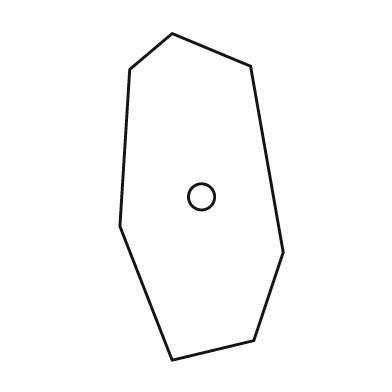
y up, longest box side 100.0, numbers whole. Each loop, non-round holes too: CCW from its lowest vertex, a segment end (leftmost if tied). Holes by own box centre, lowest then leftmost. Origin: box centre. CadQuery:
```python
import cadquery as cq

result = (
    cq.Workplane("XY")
    .moveTo(-9.0, -50.0)
    .lineTo(16.0, -44.0)
    .lineTo(25.0, -17.0)
    .lineTo(15.0, 40.0)
    .lineTo(-9.0, 50.0)
    .lineTo(-22.0, 39.0)
    .lineTo(-25.0, -9.0)
    .close()
    .moveTo(0.0, 0.0)
    .circle(4.0)
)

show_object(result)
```